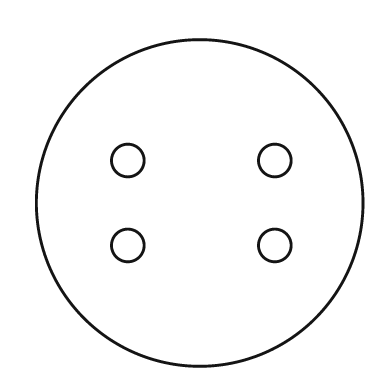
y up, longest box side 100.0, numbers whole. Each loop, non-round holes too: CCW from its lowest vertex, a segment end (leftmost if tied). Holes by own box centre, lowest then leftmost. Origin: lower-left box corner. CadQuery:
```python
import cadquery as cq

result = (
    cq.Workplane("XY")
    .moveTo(50.0, 50.0)
    .circle(50.0)
    .moveTo(28.0, 37.0)
    .circle(5.0)
    .moveTo(73.0, 37.0)
    .circle(5.0)
    .moveTo(28.0, 63.0)
    .circle(5.0)
    .moveTo(73.0, 63.0)
    .circle(5.0)
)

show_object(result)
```